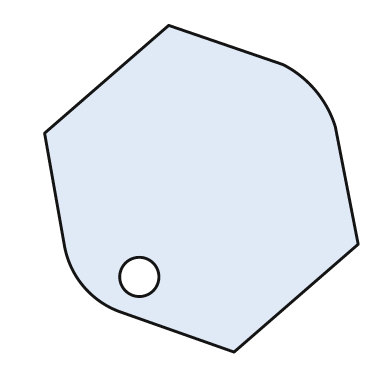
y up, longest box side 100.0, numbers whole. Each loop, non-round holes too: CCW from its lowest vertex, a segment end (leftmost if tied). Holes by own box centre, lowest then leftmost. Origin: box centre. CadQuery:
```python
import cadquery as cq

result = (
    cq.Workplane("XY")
    .moveTo(10.0, -50.0)
    .lineTo(48.0, -17.0)
    .lineTo(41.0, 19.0)
    .threePointArc((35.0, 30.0), (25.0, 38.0))
    .lineTo(-10.0, 50.0)
    .lineTo(-48.0, 17.0)
    .lineTo(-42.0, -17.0)
    .threePointArc((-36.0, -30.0), (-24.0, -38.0))
    .close()
    .moveTo(-19.0, -27.0)
    .circle(6.0)
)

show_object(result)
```